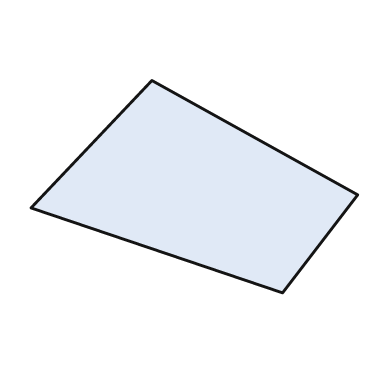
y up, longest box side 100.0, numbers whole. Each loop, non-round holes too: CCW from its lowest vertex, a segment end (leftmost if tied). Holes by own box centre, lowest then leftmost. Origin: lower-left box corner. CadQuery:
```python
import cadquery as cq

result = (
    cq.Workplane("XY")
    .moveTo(77.0, 0.0)
    .lineTo(100.0, 30.0)
    .lineTo(37.0, 65.0)
    .lineTo(0.0, 26.0)
    .close()
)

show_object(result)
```